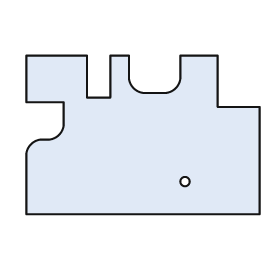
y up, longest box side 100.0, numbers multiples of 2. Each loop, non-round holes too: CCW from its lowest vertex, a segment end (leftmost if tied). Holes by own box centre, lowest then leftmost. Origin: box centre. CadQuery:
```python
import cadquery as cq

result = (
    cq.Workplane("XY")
    .moveTo(-50.0, -34.0)
    .lineTo(50.0, -34.0)
    .lineTo(50.0, 12.0)
    .lineTo(32.0, 12.0)
    .lineTo(32.0, 34.0)
    .lineTo(16.0, 34.0)
    .lineTo(16.0, 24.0)
    .threePointArc((14.0, 20.0), (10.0, 18.0))
    .lineTo(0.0, 18.0)
    .threePointArc((-4.0, 20.0), (-6.0, 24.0))
    .lineTo(-6.0, 34.0)
    .lineTo(-14.0, 34.0)
    .lineTo(-14.0, 16.0)
    .lineTo(-24.0, 16.0)
    .lineTo(-24.0, 34.0)
    .lineTo(-50.0, 34.0)
    .lineTo(-50.0, 14.0)
    .lineTo(-34.0, 14.0)
    .lineTo(-34.0, 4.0)
    .threePointArc((-36.0, 0.0), (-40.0, -2.0))
    .lineTo(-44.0, -2.0)
    .threePointArc((-48.0, -4.0), (-50.0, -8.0))
    .close()
    .moveTo(18.0, -20.0)
    .circle(2.0)
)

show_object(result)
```